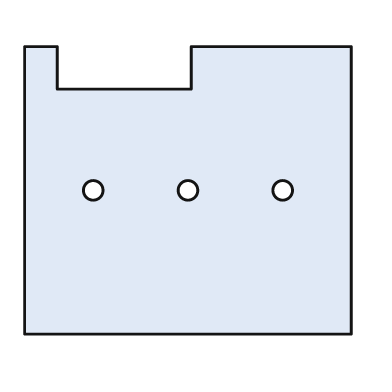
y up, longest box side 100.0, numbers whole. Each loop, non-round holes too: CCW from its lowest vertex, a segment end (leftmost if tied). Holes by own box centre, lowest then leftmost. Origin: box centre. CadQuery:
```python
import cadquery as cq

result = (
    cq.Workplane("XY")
    .moveTo(-50.0, -44.0)
    .lineTo(50.0, -44.0)
    .lineTo(50.0, 44.0)
    .lineTo(1.0, 44.0)
    .lineTo(1.0, 31.0)
    .lineTo(-40.0, 31.0)
    .lineTo(-40.0, 44.0)
    .lineTo(-50.0, 44.0)
    .close()
    .moveTo(-29.0, 0.0)
    .circle(3.0)
    .moveTo(0.0, 0.0)
    .circle(3.0)
    .moveTo(29.0, 0.0)
    .circle(3.0)
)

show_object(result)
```